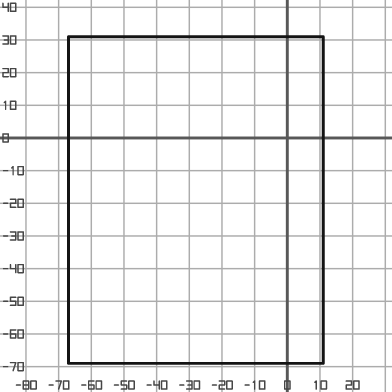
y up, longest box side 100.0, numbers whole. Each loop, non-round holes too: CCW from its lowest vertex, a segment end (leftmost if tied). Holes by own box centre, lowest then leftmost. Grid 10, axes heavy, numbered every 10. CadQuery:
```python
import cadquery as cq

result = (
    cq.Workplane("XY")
    .moveTo(-67.0, -69.0)
    .lineTo(11.0, -69.0)
    .lineTo(11.0, 31.0)
    .lineTo(-67.0, 31.0)
    .close()
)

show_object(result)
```